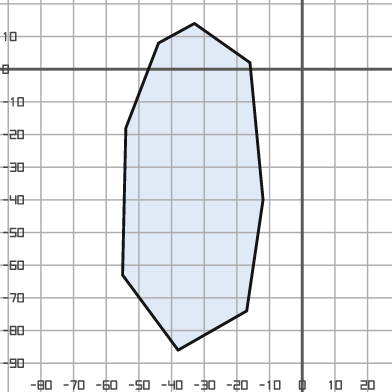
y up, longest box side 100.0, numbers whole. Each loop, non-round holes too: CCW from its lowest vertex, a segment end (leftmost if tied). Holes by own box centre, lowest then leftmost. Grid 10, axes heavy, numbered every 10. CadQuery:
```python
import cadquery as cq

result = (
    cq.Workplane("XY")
    .moveTo(-38.0, -86.0)
    .lineTo(-17.0, -74.0)
    .lineTo(-12.0, -40.0)
    .lineTo(-16.0, 2.0)
    .lineTo(-33.0, 14.0)
    .lineTo(-44.0, 8.0)
    .lineTo(-54.0, -18.0)
    .lineTo(-55.0, -63.0)
    .close()
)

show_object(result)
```